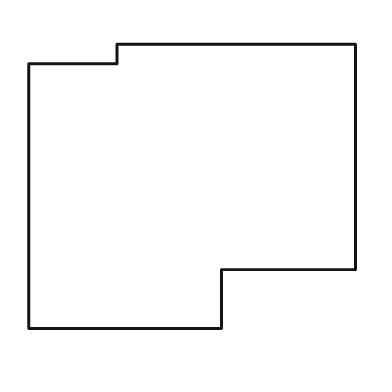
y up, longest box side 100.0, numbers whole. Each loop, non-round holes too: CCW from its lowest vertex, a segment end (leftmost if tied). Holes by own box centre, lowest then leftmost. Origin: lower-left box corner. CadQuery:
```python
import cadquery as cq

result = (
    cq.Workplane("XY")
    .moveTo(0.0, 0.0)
    .lineTo(59.0, 0.0)
    .lineTo(59.0, 18.0)
    .lineTo(100.0, 18.0)
    .lineTo(100.0, 87.0)
    .lineTo(27.0, 87.0)
    .lineTo(27.0, 81.0)
    .lineTo(0.0, 81.0)
    .close()
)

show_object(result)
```